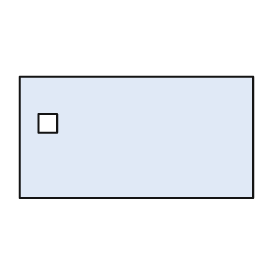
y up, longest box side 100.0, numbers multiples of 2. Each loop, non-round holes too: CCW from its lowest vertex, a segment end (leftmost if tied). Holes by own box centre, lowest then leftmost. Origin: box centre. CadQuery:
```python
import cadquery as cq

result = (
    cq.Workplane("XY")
    .moveTo(-50.0, -26.0)
    .lineTo(50.0, -26.0)
    .lineTo(50.0, 26.0)
    .lineTo(-50.0, 26.0)
    .close()
    .moveTo(-42.0, 2.0)
    .lineTo(-34.0, 2.0)
    .lineTo(-34.0, 10.0)
    .lineTo(-42.0, 10.0)
    .close()
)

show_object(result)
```